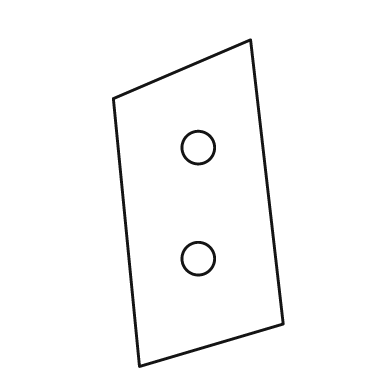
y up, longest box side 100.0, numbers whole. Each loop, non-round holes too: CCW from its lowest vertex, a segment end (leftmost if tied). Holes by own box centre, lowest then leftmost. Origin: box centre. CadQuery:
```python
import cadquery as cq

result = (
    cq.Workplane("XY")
    .moveTo(-18.0, -50.0)
    .lineTo(26.0, -37.0)
    .lineTo(16.0, 50.0)
    .lineTo(-26.0, 32.0)
    .close()
    .moveTo(0.0, -17.0)
    .circle(5.0)
    .moveTo(0.0, 17.0)
    .circle(5.0)
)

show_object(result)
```